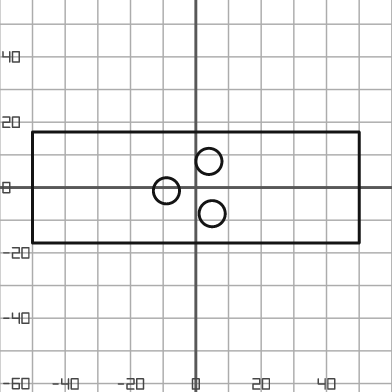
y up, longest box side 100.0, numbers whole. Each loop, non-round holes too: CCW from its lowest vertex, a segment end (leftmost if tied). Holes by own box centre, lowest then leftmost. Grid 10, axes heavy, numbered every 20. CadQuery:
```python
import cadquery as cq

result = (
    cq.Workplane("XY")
    .moveTo(-50.0, -17.0)
    .lineTo(50.0, -17.0)
    .lineTo(50.0, 17.0)
    .lineTo(-50.0, 17.0)
    .close()
    .moveTo(5.0, -8.0)
    .circle(4.0)
    .moveTo(-9.0, -1.0)
    .circle(4.0)
    .moveTo(4.0, 8.0)
    .circle(4.0)
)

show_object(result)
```